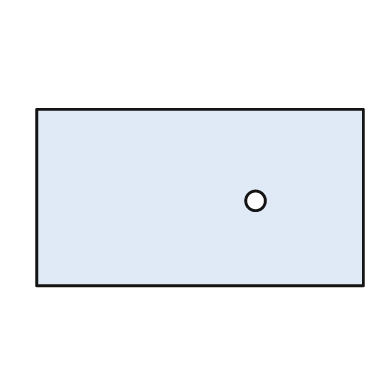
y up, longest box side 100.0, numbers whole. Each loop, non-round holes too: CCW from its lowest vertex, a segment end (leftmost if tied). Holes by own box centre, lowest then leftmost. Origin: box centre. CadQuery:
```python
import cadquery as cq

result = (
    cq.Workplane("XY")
    .moveTo(-50.0, -27.0)
    .lineTo(50.0, -27.0)
    .lineTo(50.0, 27.0)
    .lineTo(-50.0, 27.0)
    .close()
    .moveTo(17.0, -1.0)
    .circle(3.0)
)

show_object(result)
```